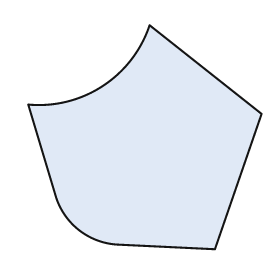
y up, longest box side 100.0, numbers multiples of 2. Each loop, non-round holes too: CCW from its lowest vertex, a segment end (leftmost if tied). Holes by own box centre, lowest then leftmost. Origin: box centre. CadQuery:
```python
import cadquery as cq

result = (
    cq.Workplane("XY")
    .moveTo(30.0, -48.0)
    .lineTo(50.0, 10.0)
    .lineTo(2.0, 48.0)
    .threePointArc((-18.0, 22.0), (-50.0, 14.0))
    .lineTo(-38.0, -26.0)
    .threePointArc((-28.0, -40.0), (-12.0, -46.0))
    .close()
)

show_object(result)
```